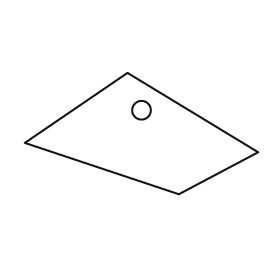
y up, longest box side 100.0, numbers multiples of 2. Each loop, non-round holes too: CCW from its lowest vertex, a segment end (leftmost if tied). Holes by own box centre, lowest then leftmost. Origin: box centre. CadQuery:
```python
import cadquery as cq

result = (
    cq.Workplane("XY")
    .moveTo(16.0, -26.0)
    .lineTo(50.0, -8.0)
    .lineTo(-6.0, 26.0)
    .lineTo(-50.0, -4.0)
    .close()
    .moveTo(0.0, 10.0)
    .circle(4.0)
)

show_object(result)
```